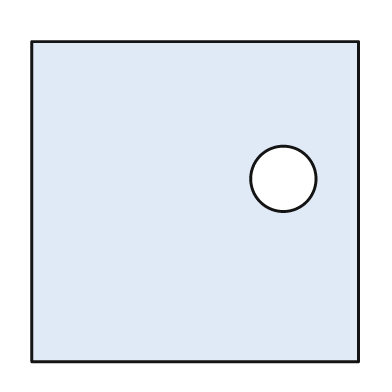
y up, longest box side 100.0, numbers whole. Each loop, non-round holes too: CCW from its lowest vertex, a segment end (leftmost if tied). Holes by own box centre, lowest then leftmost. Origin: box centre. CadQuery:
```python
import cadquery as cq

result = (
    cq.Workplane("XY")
    .moveTo(-50.0, -49.0)
    .lineTo(50.0, -49.0)
    .lineTo(50.0, 49.0)
    .lineTo(-50.0, 49.0)
    .close()
    .moveTo(27.0, 7.0)
    .circle(10.0)
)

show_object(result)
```